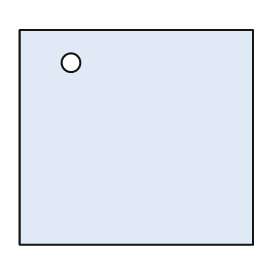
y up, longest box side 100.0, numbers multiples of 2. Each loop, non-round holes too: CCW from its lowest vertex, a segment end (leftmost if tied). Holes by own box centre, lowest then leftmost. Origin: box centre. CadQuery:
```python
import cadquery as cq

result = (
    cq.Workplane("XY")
    .moveTo(-50.0, -46.0)
    .lineTo(50.0, -46.0)
    .lineTo(50.0, 46.0)
    .lineTo(-50.0, 46.0)
    .close()
    .moveTo(-28.0, 32.0)
    .circle(4.0)
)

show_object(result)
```